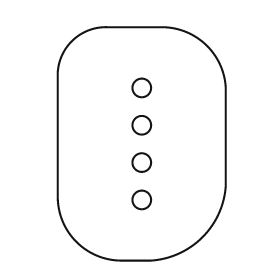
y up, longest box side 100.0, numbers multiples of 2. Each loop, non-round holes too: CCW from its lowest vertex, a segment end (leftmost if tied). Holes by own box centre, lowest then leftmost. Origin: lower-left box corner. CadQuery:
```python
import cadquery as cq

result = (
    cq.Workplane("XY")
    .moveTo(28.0, 0.0)
    .lineTo(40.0, 0.0)
    .threePointArc((62.0, 10.0), (72.0, 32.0))
    .lineTo(72.0, 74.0)
    .threePointArc((64.0, 92.0), (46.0, 100.0))
    .lineTo(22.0, 100.0)
    .threePointArc((6.0, 94.0), (0.0, 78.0))
    .lineTo(0.0, 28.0)
    .threePointArc((8.0, 8.0), (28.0, 0.0))
    .close()
    .moveTo(36.0, 26.0)
    .circle(4.0)
    .moveTo(36.0, 42.0)
    .circle(4.0)
    .moveTo(36.0, 58.0)
    .circle(4.0)
    .moveTo(36.0, 74.0)
    .circle(4.0)
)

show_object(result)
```